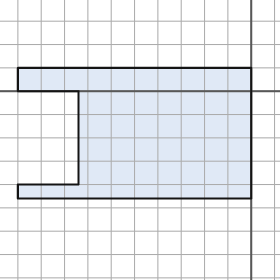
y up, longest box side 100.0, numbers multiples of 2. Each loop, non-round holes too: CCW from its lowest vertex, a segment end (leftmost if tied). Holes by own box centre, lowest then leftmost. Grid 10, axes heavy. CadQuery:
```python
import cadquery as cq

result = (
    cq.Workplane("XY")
    .moveTo(-100.0, -46.0)
    .lineTo(0.0, -46.0)
    .lineTo(0.0, 10.0)
    .lineTo(-100.0, 10.0)
    .lineTo(-100.0, 0.0)
    .lineTo(-74.0, 0.0)
    .lineTo(-74.0, -40.0)
    .lineTo(-100.0, -40.0)
    .close()
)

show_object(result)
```